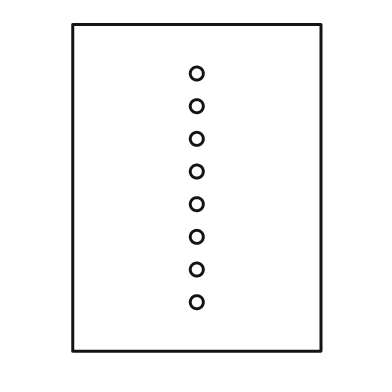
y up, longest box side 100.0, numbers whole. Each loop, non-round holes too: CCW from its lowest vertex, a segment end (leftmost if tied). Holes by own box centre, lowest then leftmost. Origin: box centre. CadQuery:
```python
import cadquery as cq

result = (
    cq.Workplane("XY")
    .moveTo(-38.0, -50.0)
    .lineTo(38.0, -50.0)
    .lineTo(38.0, 50.0)
    .lineTo(-38.0, 50.0)
    .close()
    .moveTo(0.0, -35.0)
    .circle(2.0)
    .moveTo(0.0, -25.0)
    .circle(2.0)
    .moveTo(0.0, -15.0)
    .circle(2.0)
    .moveTo(0.0, -5.0)
    .circle(2.0)
    .moveTo(0.0, 5.0)
    .circle(2.0)
    .moveTo(0.0, 15.0)
    .circle(2.0)
    .moveTo(0.0, 25.0)
    .circle(2.0)
    .moveTo(0.0, 35.0)
    .circle(2.0)
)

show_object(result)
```